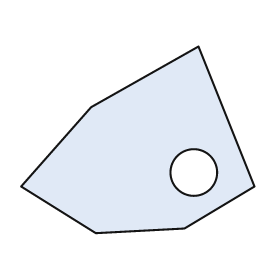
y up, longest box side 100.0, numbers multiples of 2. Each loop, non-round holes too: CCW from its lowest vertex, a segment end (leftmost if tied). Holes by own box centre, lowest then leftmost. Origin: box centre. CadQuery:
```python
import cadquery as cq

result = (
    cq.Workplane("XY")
    .moveTo(-18.0, -40.0)
    .lineTo(20.0, -38.0)
    .lineTo(50.0, -20.0)
    .lineTo(26.0, 40.0)
    .lineTo(-20.0, 14.0)
    .lineTo(-50.0, -20.0)
    .close()
    .moveTo(24.0, -14.0)
    .circle(10.0)
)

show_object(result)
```